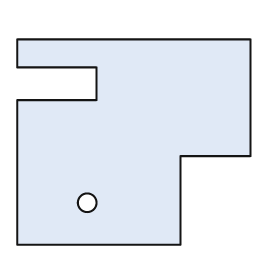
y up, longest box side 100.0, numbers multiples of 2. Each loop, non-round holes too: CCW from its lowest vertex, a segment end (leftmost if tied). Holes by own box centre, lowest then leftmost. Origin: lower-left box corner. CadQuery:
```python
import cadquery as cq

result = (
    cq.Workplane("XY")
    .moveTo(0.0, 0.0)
    .lineTo(70.0, 0.0)
    .lineTo(70.0, 38.0)
    .lineTo(100.0, 38.0)
    .lineTo(100.0, 88.0)
    .lineTo(0.0, 88.0)
    .lineTo(0.0, 76.0)
    .lineTo(34.0, 76.0)
    .lineTo(34.0, 62.0)
    .lineTo(0.0, 62.0)
    .close()
    .moveTo(30.0, 18.0)
    .circle(4.0)
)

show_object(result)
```